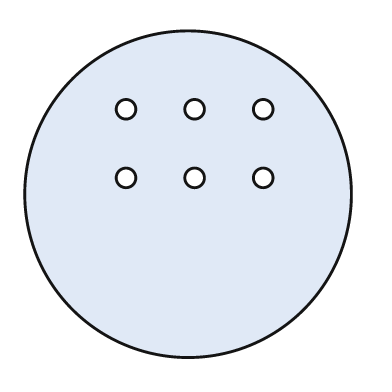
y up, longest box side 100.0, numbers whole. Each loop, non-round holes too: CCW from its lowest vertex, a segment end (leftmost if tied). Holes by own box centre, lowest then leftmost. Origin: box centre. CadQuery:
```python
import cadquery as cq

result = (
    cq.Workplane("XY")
    .moveTo(0.0, 0.0)
    .circle(50.0)
    .moveTo(-19.0, 5.0)
    .circle(3.0)
    .moveTo(2.0, 5.0)
    .circle(3.0)
    .moveTo(23.0, 5.0)
    .circle(3.0)
    .moveTo(-19.0, 26.0)
    .circle(3.0)
    .moveTo(2.0, 26.0)
    .circle(3.0)
    .moveTo(23.0, 26.0)
    .circle(3.0)
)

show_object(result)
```